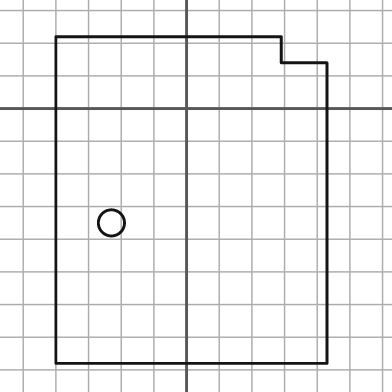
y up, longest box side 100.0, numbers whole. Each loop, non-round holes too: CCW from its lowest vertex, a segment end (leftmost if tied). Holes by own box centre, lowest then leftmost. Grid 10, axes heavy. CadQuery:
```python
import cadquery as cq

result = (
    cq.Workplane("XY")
    .moveTo(-40.0, -78.0)
    .lineTo(43.0, -78.0)
    .lineTo(43.0, 14.0)
    .lineTo(29.0, 14.0)
    .lineTo(29.0, 22.0)
    .lineTo(-40.0, 22.0)
    .close()
    .moveTo(-23.0, -35.0)
    .circle(4.0)
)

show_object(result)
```